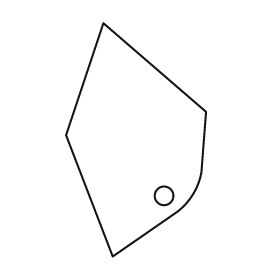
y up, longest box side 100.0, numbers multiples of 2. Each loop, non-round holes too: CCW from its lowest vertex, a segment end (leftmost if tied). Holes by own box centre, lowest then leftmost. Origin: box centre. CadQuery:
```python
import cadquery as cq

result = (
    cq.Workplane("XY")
    .moveTo(-10.0, -50.0)
    .lineTo(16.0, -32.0)
    .threePointArc((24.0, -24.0), (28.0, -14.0))
    .lineTo(30.0, 12.0)
    .lineTo(-14.0, 50.0)
    .lineTo(-30.0, 2.0)
    .close()
    .moveTo(12.0, -24.0)
    .circle(4.0)
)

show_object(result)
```